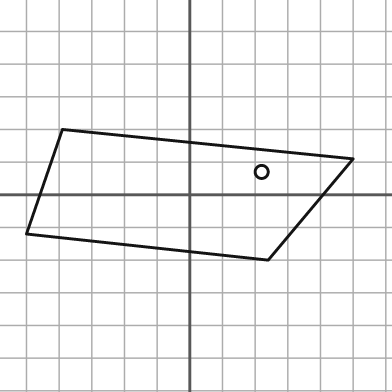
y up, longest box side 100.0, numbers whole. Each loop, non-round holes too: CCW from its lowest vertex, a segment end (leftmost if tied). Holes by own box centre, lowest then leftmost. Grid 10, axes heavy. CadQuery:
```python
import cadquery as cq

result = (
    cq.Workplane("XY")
    .moveTo(24.0, -20.0)
    .lineTo(50.0, 11.0)
    .lineTo(-39.0, 20.0)
    .lineTo(-50.0, -12.0)
    .close()
    .moveTo(22.0, 7.0)
    .circle(2.0)
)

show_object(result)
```